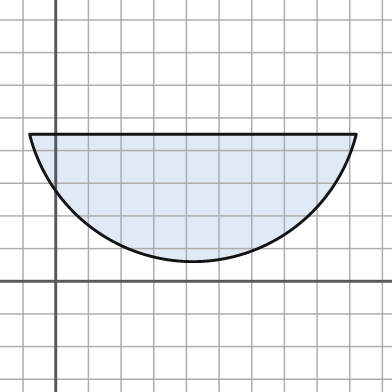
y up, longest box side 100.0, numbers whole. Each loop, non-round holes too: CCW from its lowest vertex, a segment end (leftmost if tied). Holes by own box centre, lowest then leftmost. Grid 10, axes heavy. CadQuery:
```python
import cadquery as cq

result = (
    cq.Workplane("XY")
    .moveTo(-8.0, 45.0)
    .threePointArc((42.0, 6.0), (92.0, 45.0))
    .close()
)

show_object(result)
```